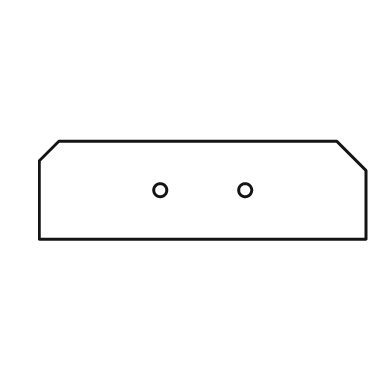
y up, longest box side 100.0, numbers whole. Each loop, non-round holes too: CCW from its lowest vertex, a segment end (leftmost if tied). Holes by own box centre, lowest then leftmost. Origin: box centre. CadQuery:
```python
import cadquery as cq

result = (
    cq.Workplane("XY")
    .moveTo(-50.0, -15.0)
    .lineTo(50.0, -15.0)
    .lineTo(50.0, 6.0)
    .lineTo(41.0, 15.0)
    .lineTo(-44.0, 15.0)
    .lineTo(-50.0, 9.0)
    .close()
    .moveTo(-13.0, 0.0)
    .circle(2.0)
    .moveTo(13.0, 0.0)
    .circle(2.0)
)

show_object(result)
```